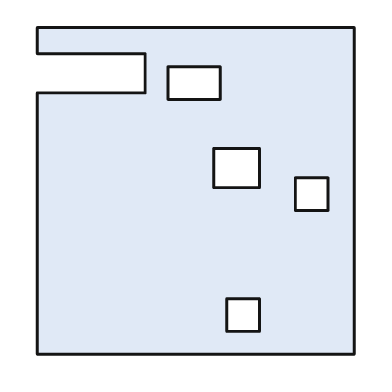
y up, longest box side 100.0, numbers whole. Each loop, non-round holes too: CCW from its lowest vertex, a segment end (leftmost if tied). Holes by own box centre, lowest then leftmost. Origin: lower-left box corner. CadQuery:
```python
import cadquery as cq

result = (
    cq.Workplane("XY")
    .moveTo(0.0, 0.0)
    .lineTo(97.0, 0.0)
    .lineTo(97.0, 100.0)
    .lineTo(0.0, 100.0)
    .lineTo(0.0, 92.0)
    .lineTo(33.0, 92.0)
    .lineTo(33.0, 80.0)
    .lineTo(0.0, 80.0)
    .close()
    .moveTo(58.0, 7.0)
    .lineTo(68.0, 7.0)
    .lineTo(68.0, 17.0)
    .lineTo(58.0, 17.0)
    .close()
    .moveTo(79.0, 44.0)
    .lineTo(89.0, 44.0)
    .lineTo(89.0, 54.0)
    .lineTo(79.0, 54.0)
    .close()
    .moveTo(54.0, 51.0)
    .lineTo(68.0, 51.0)
    .lineTo(68.0, 63.0)
    .lineTo(54.0, 63.0)
    .close()
    .moveTo(40.0, 78.0)
    .lineTo(56.0, 78.0)
    .lineTo(56.0, 88.0)
    .lineTo(40.0, 88.0)
    .close()
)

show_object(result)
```